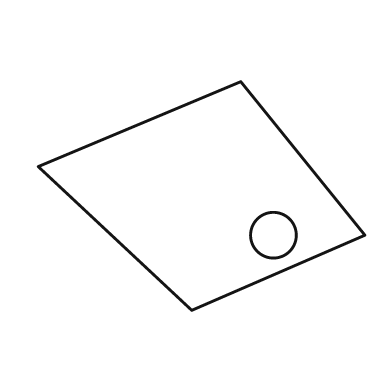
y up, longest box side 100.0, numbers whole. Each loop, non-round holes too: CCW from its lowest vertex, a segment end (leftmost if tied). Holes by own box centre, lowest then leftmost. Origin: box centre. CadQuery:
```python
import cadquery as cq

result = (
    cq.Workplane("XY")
    .moveTo(-3.0, -35.0)
    .lineTo(50.0, -12.0)
    .lineTo(12.0, 35.0)
    .lineTo(-50.0, 9.0)
    .close()
    .moveTo(22.0, -12.0)
    .circle(7.0)
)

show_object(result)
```